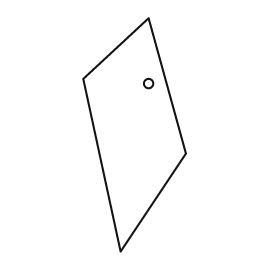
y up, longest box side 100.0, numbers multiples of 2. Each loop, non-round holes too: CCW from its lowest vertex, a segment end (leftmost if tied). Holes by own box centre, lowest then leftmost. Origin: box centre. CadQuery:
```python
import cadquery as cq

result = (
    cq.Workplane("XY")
    .moveTo(-6.0, -50.0)
    .lineTo(22.0, -8.0)
    .lineTo(6.0, 50.0)
    .lineTo(-22.0, 24.0)
    .close()
    .moveTo(6.0, 22.0)
    .circle(2.0)
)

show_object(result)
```